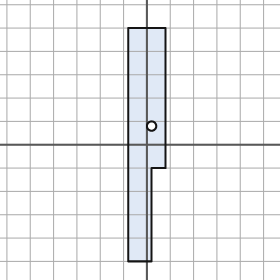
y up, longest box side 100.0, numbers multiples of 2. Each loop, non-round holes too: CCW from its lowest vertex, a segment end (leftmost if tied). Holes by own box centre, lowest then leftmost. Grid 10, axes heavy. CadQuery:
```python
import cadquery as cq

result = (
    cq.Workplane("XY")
    .moveTo(-8.0, -50.0)
    .lineTo(2.0, -50.0)
    .lineTo(2.0, -10.0)
    .lineTo(8.0, -10.0)
    .lineTo(8.0, 50.0)
    .lineTo(-8.0, 50.0)
    .close()
    .moveTo(2.0, 8.0)
    .circle(2.0)
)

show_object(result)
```